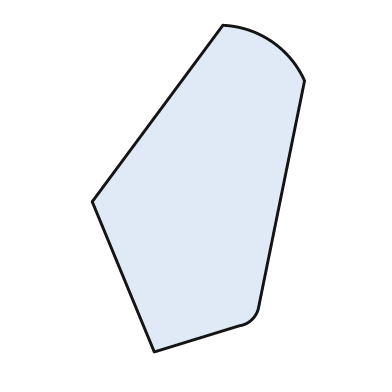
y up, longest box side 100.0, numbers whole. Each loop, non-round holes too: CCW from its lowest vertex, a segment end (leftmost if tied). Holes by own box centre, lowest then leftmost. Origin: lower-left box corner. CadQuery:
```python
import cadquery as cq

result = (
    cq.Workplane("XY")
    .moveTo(19.0, 0.0)
    .lineTo(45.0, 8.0)
    .threePointArc((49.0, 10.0), (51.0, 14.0))
    .lineTo(65.0, 83.0)
    .threePointArc((55.0, 95.0), (40.0, 100.0))
    .lineTo(0.0, 46.0)
    .close()
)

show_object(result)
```